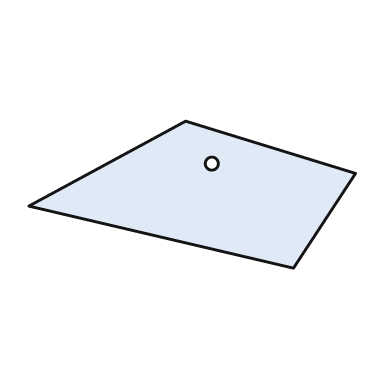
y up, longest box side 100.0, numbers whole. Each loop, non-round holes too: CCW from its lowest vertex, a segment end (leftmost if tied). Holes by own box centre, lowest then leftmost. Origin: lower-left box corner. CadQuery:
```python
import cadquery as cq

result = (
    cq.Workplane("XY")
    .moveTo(81.0, 0.0)
    .lineTo(100.0, 29.0)
    .lineTo(48.0, 45.0)
    .lineTo(0.0, 19.0)
    .close()
    .moveTo(56.0, 32.0)
    .circle(2.0)
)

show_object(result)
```